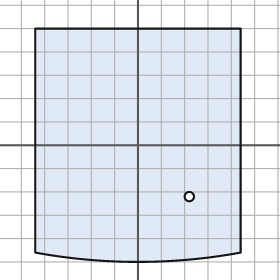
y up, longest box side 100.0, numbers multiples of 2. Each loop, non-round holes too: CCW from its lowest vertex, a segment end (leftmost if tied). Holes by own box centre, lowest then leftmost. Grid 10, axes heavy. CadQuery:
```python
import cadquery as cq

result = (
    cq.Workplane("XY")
    .moveTo(-44.0, -46.0)
    .threePointArc((0.0, -50.0), (44.0, -46.0))
    .lineTo(44.0, 50.0)
    .lineTo(-44.0, 50.0)
    .close()
    .moveTo(22.0, -22.0)
    .circle(2.0)
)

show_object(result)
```